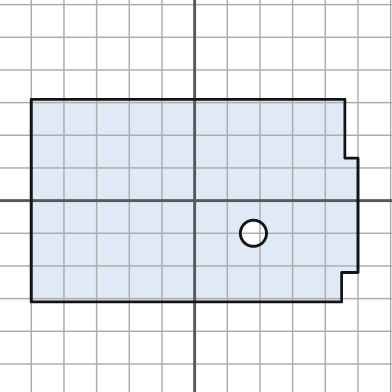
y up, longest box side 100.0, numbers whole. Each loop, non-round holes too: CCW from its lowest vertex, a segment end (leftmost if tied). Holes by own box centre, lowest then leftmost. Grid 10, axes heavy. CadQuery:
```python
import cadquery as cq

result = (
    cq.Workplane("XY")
    .moveTo(-50.0, -31.0)
    .lineTo(45.0, -31.0)
    .lineTo(45.0, -22.0)
    .lineTo(50.0, -22.0)
    .lineTo(50.0, 13.0)
    .lineTo(46.0, 13.0)
    .lineTo(46.0, 31.0)
    .lineTo(-50.0, 31.0)
    .close()
    .moveTo(18.0, -10.0)
    .circle(4.0)
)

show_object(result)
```